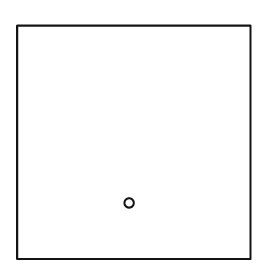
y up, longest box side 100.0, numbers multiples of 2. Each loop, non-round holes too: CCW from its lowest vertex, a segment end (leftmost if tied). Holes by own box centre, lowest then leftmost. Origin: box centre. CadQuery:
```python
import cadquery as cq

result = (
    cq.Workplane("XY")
    .moveTo(-50.0, -50.0)
    .lineTo(50.0, -50.0)
    .lineTo(50.0, 50.0)
    .lineTo(-50.0, 50.0)
    .close()
    .moveTo(-2.0, -26.0)
    .circle(2.0)
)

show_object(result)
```